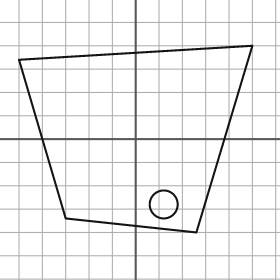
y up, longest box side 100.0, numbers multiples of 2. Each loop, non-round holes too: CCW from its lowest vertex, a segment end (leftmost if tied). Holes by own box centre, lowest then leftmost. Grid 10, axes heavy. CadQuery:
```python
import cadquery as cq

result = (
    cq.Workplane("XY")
    .moveTo(26.0, -40.0)
    .lineTo(50.0, 40.0)
    .lineTo(-50.0, 34.0)
    .lineTo(-30.0, -34.0)
    .close()
    .moveTo(12.0, -28.0)
    .circle(6.0)
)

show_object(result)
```